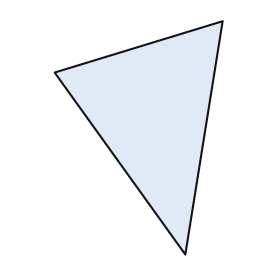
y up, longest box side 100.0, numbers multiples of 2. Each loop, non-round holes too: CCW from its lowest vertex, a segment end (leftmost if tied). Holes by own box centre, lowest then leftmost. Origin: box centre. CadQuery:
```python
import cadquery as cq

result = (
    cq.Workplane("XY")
    .moveTo(20.0, -50.0)
    .lineTo(36.0, 50.0)
    .lineTo(-36.0, 28.0)
    .close()
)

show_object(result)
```